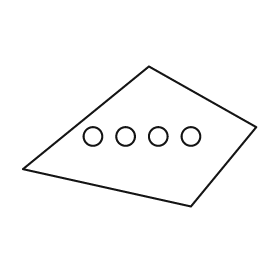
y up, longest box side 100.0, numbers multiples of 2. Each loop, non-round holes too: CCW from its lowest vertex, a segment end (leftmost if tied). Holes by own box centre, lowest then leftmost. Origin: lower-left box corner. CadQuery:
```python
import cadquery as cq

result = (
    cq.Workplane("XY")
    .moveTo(72.0, 0.0)
    .lineTo(100.0, 34.0)
    .lineTo(54.0, 60.0)
    .lineTo(0.0, 16.0)
    .close()
    .moveTo(30.0, 30.0)
    .circle(4.0)
    .moveTo(44.0, 30.0)
    .circle(4.0)
    .moveTo(58.0, 30.0)
    .circle(4.0)
    .moveTo(72.0, 30.0)
    .circle(4.0)
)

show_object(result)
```